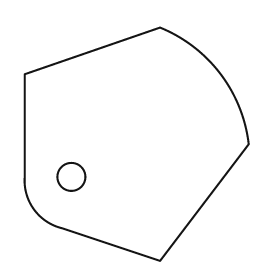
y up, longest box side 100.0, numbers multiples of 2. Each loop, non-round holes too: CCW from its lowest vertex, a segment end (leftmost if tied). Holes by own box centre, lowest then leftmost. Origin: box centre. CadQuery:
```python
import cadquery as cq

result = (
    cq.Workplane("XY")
    .moveTo(10.0, -50.0)
    .lineTo(48.0, 0.0)
    .threePointArc((36.0, 30.0), (10.0, 50.0))
    .lineTo(-48.0, 30.0)
    .lineTo(-48.0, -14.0)
    .threePointArc((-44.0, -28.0), (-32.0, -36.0))
    .close()
    .moveTo(-28.0, -14.0)
    .circle(6.0)
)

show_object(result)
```